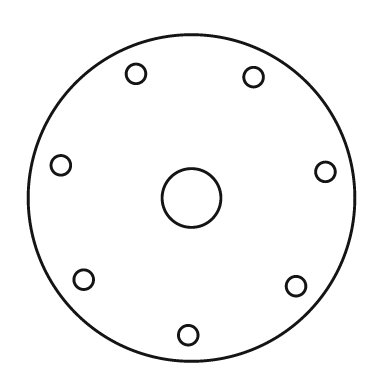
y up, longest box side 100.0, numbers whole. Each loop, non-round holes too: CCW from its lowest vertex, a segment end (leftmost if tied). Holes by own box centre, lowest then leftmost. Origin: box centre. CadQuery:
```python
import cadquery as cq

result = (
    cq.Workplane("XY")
    .moveTo(0.0, 0.0)
    .circle(50.0)
    .moveTo(-1.0, -42.0)
    .circle(3.0)
    .moveTo(32.0, -27.0)
    .circle(3.0)
    .moveTo(-33.0, -25.0)
    .circle(3.0)
    .moveTo(0.0, 0.0)
    .circle(9.0)
    .moveTo(41.0, 8.0)
    .circle(3.0)
    .moveTo(-40.0, 10.0)
    .circle(3.0)
    .moveTo(19.0, 37.0)
    .circle(3.0)
    .moveTo(-17.0, 38.0)
    .circle(3.0)
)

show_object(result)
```